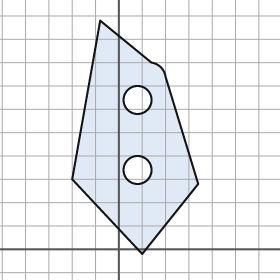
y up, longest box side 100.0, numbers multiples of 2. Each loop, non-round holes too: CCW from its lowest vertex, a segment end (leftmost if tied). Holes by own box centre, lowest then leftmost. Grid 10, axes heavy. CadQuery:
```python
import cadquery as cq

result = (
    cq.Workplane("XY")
    .moveTo(10.0, -2.0)
    .lineTo(34.0, 28.0)
    .lineTo(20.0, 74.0)
    .threePointArc((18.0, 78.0), (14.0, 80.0))
    .lineTo(-8.0, 98.0)
    .lineTo(-20.0, 30.0)
    .close()
    .moveTo(8.0, 34.0)
    .circle(6.0)
    .moveTo(8.0, 64.0)
    .circle(6.0)
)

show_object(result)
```